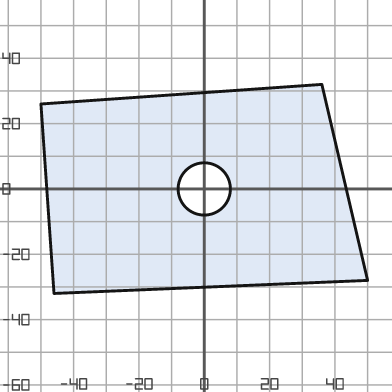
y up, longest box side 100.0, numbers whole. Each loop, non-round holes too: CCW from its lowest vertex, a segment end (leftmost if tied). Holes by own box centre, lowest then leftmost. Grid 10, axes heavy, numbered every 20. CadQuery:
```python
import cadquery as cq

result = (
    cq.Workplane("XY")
    .moveTo(-46.0, -32.0)
    .lineTo(50.0, -28.0)
    .lineTo(36.0, 32.0)
    .lineTo(-50.0, 26.0)
    .close()
    .moveTo(0.0, 0.0)
    .circle(8.0)
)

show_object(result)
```